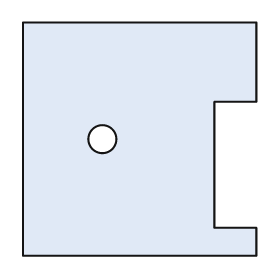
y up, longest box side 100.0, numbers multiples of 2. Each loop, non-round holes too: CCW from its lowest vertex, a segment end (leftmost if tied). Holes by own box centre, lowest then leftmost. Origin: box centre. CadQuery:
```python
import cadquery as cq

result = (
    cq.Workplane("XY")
    .moveTo(-50.0, -50.0)
    .lineTo(50.0, -50.0)
    .lineTo(50.0, -38.0)
    .lineTo(32.0, -38.0)
    .lineTo(32.0, 16.0)
    .lineTo(50.0, 16.0)
    .lineTo(50.0, 50.0)
    .lineTo(-50.0, 50.0)
    .close()
    .moveTo(-16.0, 0.0)
    .circle(6.0)
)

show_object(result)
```